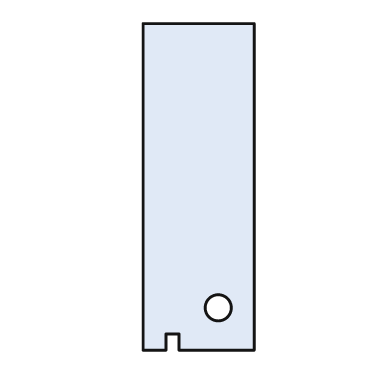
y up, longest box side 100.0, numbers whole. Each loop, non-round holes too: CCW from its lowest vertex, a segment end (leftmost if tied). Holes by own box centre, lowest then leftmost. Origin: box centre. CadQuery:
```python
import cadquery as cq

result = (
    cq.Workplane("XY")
    .moveTo(-17.0, -50.0)
    .lineTo(-10.0, -50.0)
    .lineTo(-10.0, -45.0)
    .lineTo(-6.0, -45.0)
    .lineTo(-6.0, -50.0)
    .lineTo(17.0, -50.0)
    .lineTo(17.0, 50.0)
    .lineTo(-17.0, 50.0)
    .close()
    .moveTo(6.0, -37.0)
    .circle(4.0)
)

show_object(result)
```